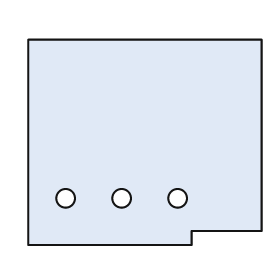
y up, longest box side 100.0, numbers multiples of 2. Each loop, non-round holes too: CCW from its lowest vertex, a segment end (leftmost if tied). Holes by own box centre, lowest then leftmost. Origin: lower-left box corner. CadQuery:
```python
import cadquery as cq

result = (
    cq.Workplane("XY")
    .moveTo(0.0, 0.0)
    .lineTo(70.0, 0.0)
    .lineTo(70.0, 6.0)
    .lineTo(100.0, 6.0)
    .lineTo(100.0, 88.0)
    .lineTo(0.0, 88.0)
    .close()
    .moveTo(16.0, 20.0)
    .circle(4.0)
    .moveTo(40.0, 20.0)
    .circle(4.0)
    .moveTo(64.0, 20.0)
    .circle(4.0)
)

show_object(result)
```